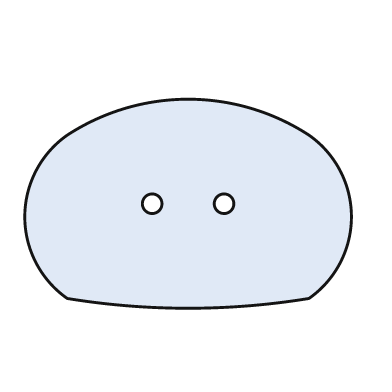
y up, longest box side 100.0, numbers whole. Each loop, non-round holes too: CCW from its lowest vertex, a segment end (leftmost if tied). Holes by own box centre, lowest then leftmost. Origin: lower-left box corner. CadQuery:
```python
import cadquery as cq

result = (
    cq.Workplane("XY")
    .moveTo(13.0, 3.0)
    .threePointArc((50.0, 0.0), (87.0, 3.0))
    .threePointArc((100.0, 28.0), (87.0, 53.0))
    .threePointArc((50.0, 64.0), (13.0, 53.0))
    .threePointArc((0.0, 28.0), (13.0, 3.0))
    .close()
    .moveTo(39.0, 32.0)
    .circle(3.0)
    .moveTo(61.0, 32.0)
    .circle(3.0)
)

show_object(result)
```